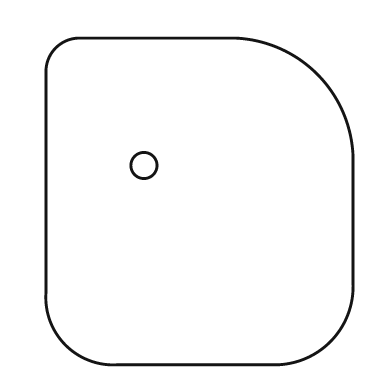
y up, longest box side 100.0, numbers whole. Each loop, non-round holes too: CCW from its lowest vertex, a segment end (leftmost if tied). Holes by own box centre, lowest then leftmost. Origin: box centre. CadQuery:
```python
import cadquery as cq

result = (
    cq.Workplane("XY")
    .moveTo(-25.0, -50.0)
    .lineTo(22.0, -50.0)
    .threePointArc((40.0, -43.0), (47.0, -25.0))
    .lineTo(47.0, 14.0)
    .threePointArc((36.0, 39.0), (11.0, 50.0))
    .lineTo(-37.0, 50.0)
    .threePointArc((-44.0, 47.0), (-47.0, 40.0))
    .lineTo(-47.0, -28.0)
    .threePointArc((-41.0, -44.0), (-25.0, -50.0))
    .close()
    .moveTo(-17.0, 11.0)
    .circle(4.0)
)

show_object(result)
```